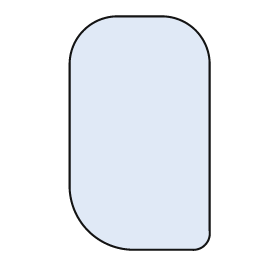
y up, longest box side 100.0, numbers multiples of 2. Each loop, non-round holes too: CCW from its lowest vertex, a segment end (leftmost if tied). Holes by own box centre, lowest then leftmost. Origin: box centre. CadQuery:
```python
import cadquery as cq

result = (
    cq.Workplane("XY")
    .moveTo(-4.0, -50.0)
    .lineTo(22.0, -50.0)
    .threePointArc((28.0, -48.0), (30.0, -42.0))
    .lineTo(30.0, 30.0)
    .threePointArc((24.0, 44.0), (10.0, 50.0))
    .lineTo(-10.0, 50.0)
    .threePointArc((-24.0, 44.0), (-30.0, 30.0))
    .lineTo(-30.0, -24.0)
    .threePointArc((-22.0, -42.0), (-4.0, -50.0))
    .close()
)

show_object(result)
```